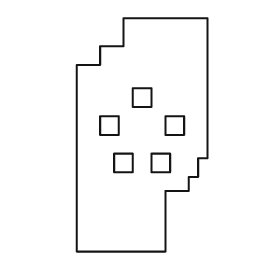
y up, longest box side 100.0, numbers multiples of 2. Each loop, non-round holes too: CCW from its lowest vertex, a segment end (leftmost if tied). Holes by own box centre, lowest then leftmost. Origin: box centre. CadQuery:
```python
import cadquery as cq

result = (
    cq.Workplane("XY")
    .moveTo(-28.0, -50.0)
    .lineTo(10.0, -50.0)
    .lineTo(10.0, -24.0)
    .lineTo(20.0, -24.0)
    .lineTo(20.0, -18.0)
    .lineTo(24.0, -18.0)
    .lineTo(24.0, -10.0)
    .lineTo(28.0, -10.0)
    .lineTo(28.0, 50.0)
    .lineTo(-8.0, 50.0)
    .lineTo(-8.0, 38.0)
    .lineTo(-18.0, 38.0)
    .lineTo(-18.0, 30.0)
    .lineTo(-28.0, 30.0)
    .close()
    .moveTo(-12.0, -16.0)
    .lineTo(-4.0, -16.0)
    .lineTo(-4.0, -8.0)
    .lineTo(-12.0, -8.0)
    .close()
    .moveTo(4.0, -16.0)
    .lineTo(12.0, -16.0)
    .lineTo(12.0, -8.0)
    .lineTo(4.0, -8.0)
    .close()
    .moveTo(-18.0, 0.0)
    .lineTo(-10.0, 0.0)
    .lineTo(-10.0, 8.0)
    .lineTo(-18.0, 8.0)
    .close()
    .moveTo(10.0, 0.0)
    .lineTo(18.0, 0.0)
    .lineTo(18.0, 8.0)
    .lineTo(10.0, 8.0)
    .close()
    .moveTo(-4.0, 12.0)
    .lineTo(4.0, 12.0)
    .lineTo(4.0, 20.0)
    .lineTo(-4.0, 20.0)
    .close()
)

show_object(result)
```